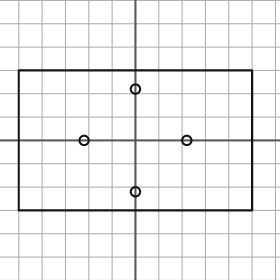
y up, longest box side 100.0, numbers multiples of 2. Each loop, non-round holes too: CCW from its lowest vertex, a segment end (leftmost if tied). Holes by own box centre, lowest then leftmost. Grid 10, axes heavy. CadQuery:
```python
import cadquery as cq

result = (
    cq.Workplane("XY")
    .moveTo(-50.0, -30.0)
    .lineTo(50.0, -30.0)
    .lineTo(50.0, 30.0)
    .lineTo(-50.0, 30.0)
    .close()
    .moveTo(0.0, -22.0)
    .circle(2.0)
    .moveTo(-22.0, 0.0)
    .circle(2.0)
    .moveTo(22.0, 0.0)
    .circle(2.0)
    .moveTo(0.0, 22.0)
    .circle(2.0)
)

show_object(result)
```